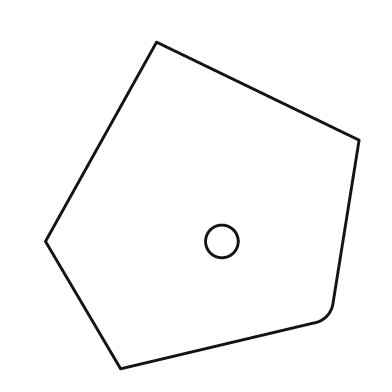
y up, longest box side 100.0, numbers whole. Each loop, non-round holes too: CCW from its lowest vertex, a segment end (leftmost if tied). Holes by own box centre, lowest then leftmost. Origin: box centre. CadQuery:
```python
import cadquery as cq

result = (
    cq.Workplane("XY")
    .moveTo(-25.0, -50.0)
    .lineTo(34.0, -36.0)
    .threePointArc((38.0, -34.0), (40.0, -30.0))
    .lineTo(48.0, 20.0)
    .lineTo(-14.0, 50.0)
    .lineTo(-48.0, -11.0)
    .close()
    .moveTo(6.0, -11.0)
    .circle(5.0)
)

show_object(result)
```